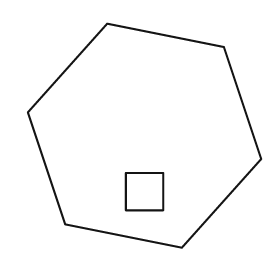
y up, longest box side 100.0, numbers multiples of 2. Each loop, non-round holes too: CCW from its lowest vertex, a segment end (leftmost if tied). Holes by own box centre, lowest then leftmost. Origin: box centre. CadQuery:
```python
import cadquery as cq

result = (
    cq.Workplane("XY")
    .moveTo(16.0, -48.0)
    .lineTo(50.0, -10.0)
    .lineTo(34.0, 38.0)
    .lineTo(-16.0, 48.0)
    .lineTo(-50.0, 10.0)
    .lineTo(-34.0, -38.0)
    .close()
    .moveTo(-8.0, -32.0)
    .lineTo(8.0, -32.0)
    .lineTo(8.0, -16.0)
    .lineTo(-8.0, -16.0)
    .close()
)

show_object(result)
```